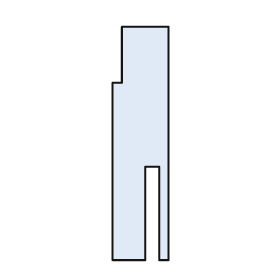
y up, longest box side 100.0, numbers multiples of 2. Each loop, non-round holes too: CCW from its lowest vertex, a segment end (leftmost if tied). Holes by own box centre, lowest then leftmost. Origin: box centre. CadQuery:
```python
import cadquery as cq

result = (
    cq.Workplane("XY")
    .moveTo(-12.0, -50.0)
    .lineTo(2.0, -50.0)
    .lineTo(2.0, -10.0)
    .lineTo(8.0, -10.0)
    .lineTo(8.0, -50.0)
    .lineTo(12.0, -50.0)
    .lineTo(12.0, 50.0)
    .lineTo(-8.0, 50.0)
    .lineTo(-8.0, 26.0)
    .lineTo(-12.0, 26.0)
    .close()
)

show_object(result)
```